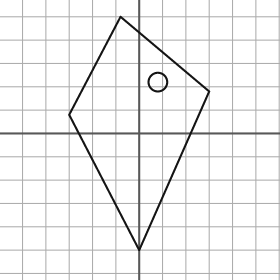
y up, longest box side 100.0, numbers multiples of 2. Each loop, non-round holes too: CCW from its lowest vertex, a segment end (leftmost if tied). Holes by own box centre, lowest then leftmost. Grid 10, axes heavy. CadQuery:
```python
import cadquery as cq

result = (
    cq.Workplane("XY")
    .moveTo(0.0, -50.0)
    .lineTo(30.0, 18.0)
    .lineTo(-8.0, 50.0)
    .lineTo(-30.0, 8.0)
    .close()
    .moveTo(8.0, 22.0)
    .circle(4.0)
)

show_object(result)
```